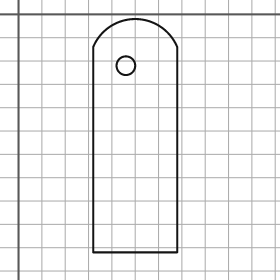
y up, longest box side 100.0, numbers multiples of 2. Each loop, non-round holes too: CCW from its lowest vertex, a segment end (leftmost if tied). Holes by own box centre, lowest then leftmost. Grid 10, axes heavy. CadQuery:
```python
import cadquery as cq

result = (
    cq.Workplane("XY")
    .moveTo(32.0, -102.0)
    .lineTo(68.0, -102.0)
    .lineTo(68.0, -14.0)
    .threePointArc((50.0, -2.0), (32.0, -14.0))
    .close()
    .moveTo(46.0, -22.0)
    .circle(4.0)
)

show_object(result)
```